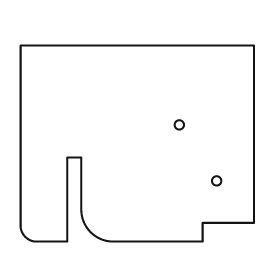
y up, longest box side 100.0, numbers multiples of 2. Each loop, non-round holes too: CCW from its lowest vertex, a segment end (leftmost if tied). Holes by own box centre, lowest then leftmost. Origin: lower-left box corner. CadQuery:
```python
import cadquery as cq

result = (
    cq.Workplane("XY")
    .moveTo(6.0, 0.0)
    .lineTo(20.0, 0.0)
    .lineTo(20.0, 36.0)
    .lineTo(26.0, 36.0)
    .lineTo(26.0, 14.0)
    .threePointArc((30.0, 4.0), (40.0, 0.0))
    .lineTo(78.0, 0.0)
    .lineTo(78.0, 8.0)
    .lineTo(100.0, 8.0)
    .lineTo(100.0, 84.0)
    .lineTo(0.0, 84.0)
    .lineTo(0.0, 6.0)
    .threePointArc((2.0, 2.0), (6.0, 0.0))
    .close()
    .moveTo(84.0, 26.0)
    .circle(2.0)
    .moveTo(68.0, 50.0)
    .circle(2.0)
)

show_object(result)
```